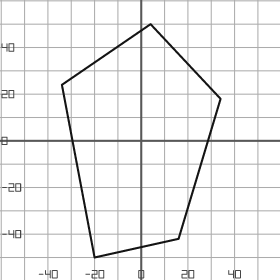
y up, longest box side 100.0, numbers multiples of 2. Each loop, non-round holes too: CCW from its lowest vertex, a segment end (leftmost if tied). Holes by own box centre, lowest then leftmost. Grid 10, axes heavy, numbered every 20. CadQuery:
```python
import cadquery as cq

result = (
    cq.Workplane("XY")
    .moveTo(-20.0, -50.0)
    .lineTo(16.0, -42.0)
    .lineTo(34.0, 18.0)
    .lineTo(4.0, 50.0)
    .lineTo(-34.0, 24.0)
    .close()
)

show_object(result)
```